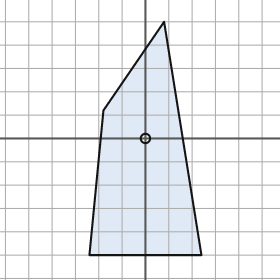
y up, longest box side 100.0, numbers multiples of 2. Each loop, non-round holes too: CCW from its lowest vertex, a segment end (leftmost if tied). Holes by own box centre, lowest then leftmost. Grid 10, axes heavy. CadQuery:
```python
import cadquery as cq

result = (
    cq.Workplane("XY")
    .moveTo(-24.0, -50.0)
    .lineTo(24.0, -50.0)
    .lineTo(8.0, 50.0)
    .lineTo(-18.0, 12.0)
    .close()
    .moveTo(0.0, 0.0)
    .circle(2.0)
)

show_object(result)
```